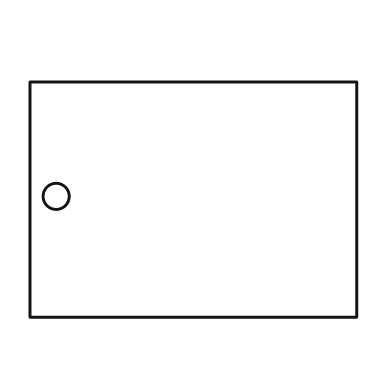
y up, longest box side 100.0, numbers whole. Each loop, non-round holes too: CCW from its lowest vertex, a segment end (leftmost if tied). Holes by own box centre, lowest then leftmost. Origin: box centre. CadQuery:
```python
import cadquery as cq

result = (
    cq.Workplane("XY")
    .moveTo(-50.0, -36.0)
    .lineTo(50.0, -36.0)
    .lineTo(50.0, 36.0)
    .lineTo(-50.0, 36.0)
    .close()
    .moveTo(-42.0, 1.0)
    .circle(4.0)
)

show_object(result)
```